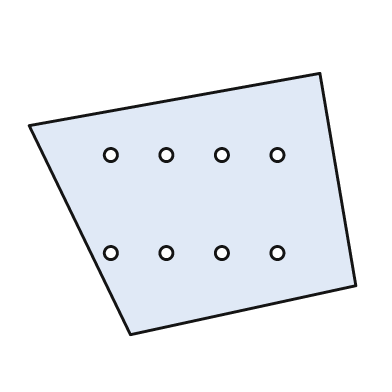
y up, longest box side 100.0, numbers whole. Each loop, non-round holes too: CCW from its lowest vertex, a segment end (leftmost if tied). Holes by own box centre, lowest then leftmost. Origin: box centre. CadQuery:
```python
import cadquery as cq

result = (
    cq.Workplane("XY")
    .moveTo(-19.0, -40.0)
    .lineTo(50.0, -25.0)
    .lineTo(39.0, 40.0)
    .lineTo(-50.0, 24.0)
    .close()
    .moveTo(-25.0, -15.0)
    .circle(2.0)
    .moveTo(-8.0, -15.0)
    .circle(2.0)
    .moveTo(9.0, -15.0)
    .circle(2.0)
    .moveTo(26.0, -15.0)
    .circle(2.0)
    .moveTo(-25.0, 15.0)
    .circle(2.0)
    .moveTo(-8.0, 15.0)
    .circle(2.0)
    .moveTo(9.0, 15.0)
    .circle(2.0)
    .moveTo(26.0, 15.0)
    .circle(2.0)
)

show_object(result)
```